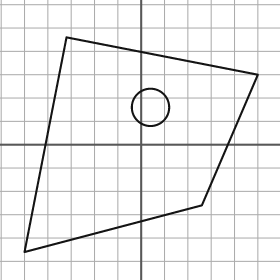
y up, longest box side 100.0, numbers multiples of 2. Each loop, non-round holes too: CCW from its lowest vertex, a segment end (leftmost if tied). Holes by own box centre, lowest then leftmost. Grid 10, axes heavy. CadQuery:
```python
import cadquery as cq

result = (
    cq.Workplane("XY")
    .moveTo(-50.0, -46.0)
    .lineTo(26.0, -26.0)
    .lineTo(50.0, 30.0)
    .lineTo(-32.0, 46.0)
    .close()
    .moveTo(4.0, 16.0)
    .circle(8.0)
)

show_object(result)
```